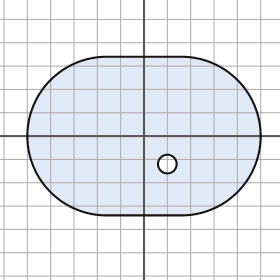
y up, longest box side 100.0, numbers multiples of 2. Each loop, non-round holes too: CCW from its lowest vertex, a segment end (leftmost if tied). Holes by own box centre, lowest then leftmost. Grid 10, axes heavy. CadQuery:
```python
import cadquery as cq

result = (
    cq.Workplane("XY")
    .moveTo(-16.0, -34.0)
    .lineTo(16.0, -34.0)
    .threePointArc((50.0, 0.0), (16.0, 34.0))
    .lineTo(-16.0, 34.0)
    .threePointArc((-50.0, 0.0), (-16.0, -34.0))
    .close()
    .moveTo(10.0, -12.0)
    .circle(4.0)
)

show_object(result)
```